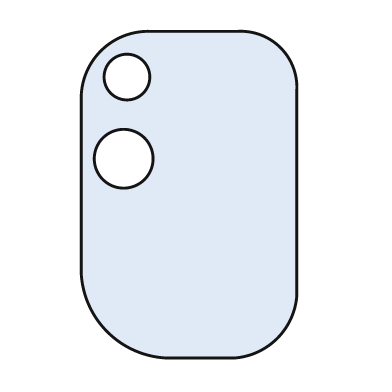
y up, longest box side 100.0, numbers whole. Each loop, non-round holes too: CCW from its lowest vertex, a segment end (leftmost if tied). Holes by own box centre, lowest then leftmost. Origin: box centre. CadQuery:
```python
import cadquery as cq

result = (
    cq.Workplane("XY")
    .moveTo(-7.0, -50.0)
    .lineTo(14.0, -50.0)
    .threePointArc((27.0, -44.0), (33.0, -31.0))
    .lineTo(33.0, 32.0)
    .threePointArc((28.0, 45.0), (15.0, 50.0))
    .lineTo(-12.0, 50.0)
    .threePointArc((-27.0, 44.0), (-33.0, 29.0))
    .lineTo(-33.0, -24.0)
    .threePointArc((-25.0, -42.0), (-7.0, -50.0))
    .close()
    .moveTo(-20.0, 11.0)
    .circle(9.0)
    .moveTo(-19.0, 36.0)
    .circle(7.0)
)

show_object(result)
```